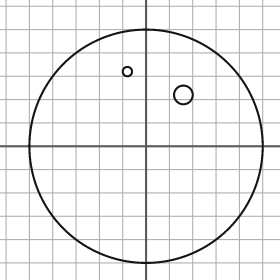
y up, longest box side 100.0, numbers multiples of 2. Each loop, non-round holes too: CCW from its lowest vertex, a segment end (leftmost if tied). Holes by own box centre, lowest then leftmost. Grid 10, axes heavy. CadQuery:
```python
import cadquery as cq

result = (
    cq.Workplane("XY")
    .moveTo(0.0, 0.0)
    .circle(50.0)
    .moveTo(16.0, 22.0)
    .circle(4.0)
    .moveTo(-8.0, 32.0)
    .circle(2.0)
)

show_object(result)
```